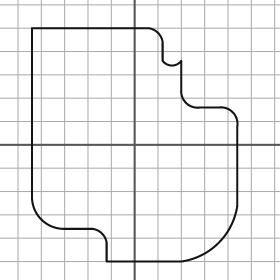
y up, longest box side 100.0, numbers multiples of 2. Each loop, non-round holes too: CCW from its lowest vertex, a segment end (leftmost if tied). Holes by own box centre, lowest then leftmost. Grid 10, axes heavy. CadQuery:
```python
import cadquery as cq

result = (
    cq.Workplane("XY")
    .moveTo(-12.0, -50.0)
    .lineTo(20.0, -50.0)
    .threePointArc((36.0, -42.0), (44.0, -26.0))
    .lineTo(44.0, 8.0)
    .threePointArc((42.0, 14.0), (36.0, 16.0))
    .lineTo(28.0, 16.0)
    .threePointArc((22.0, 18.0), (20.0, 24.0))
    .lineTo(20.0, 36.0)
    .threePointArc((16.0, 34.0), (12.0, 36.0))
    .lineTo(12.0, 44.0)
    .threePointArc((10.0, 48.0), (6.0, 50.0))
    .lineTo(-44.0, 50.0)
    .lineTo(-44.0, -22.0)
    .threePointArc((-40.0, -32.0), (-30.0, -36.0))
    .lineTo(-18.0, -36.0)
    .threePointArc((-14.0, -38.0), (-12.0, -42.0))
    .close()
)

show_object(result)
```